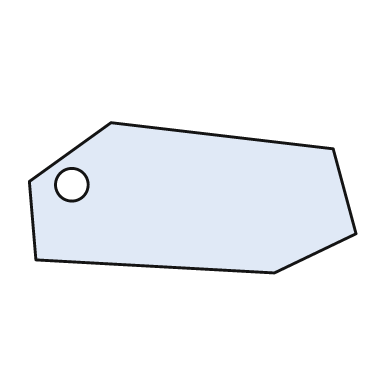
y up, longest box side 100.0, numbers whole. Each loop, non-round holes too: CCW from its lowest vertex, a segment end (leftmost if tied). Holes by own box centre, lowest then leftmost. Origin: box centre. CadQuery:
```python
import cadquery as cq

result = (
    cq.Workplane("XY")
    .moveTo(25.0, -23.0)
    .lineTo(50.0, -11.0)
    .lineTo(43.0, 15.0)
    .lineTo(-25.0, 23.0)
    .lineTo(-50.0, 5.0)
    .lineTo(-48.0, -19.0)
    .close()
    .moveTo(-37.0, 4.0)
    .circle(5.0)
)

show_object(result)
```